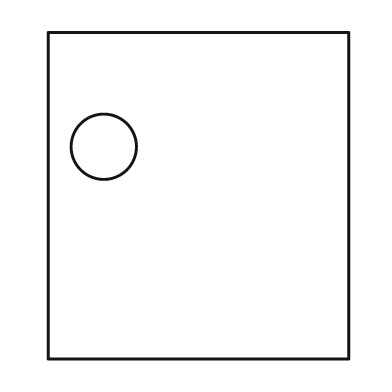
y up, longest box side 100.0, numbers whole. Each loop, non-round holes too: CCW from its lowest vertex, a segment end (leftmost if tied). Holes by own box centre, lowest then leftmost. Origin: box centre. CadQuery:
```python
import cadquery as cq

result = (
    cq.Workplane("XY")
    .moveTo(-46.0, -50.0)
    .lineTo(46.0, -50.0)
    .lineTo(46.0, 50.0)
    .lineTo(-46.0, 50.0)
    .close()
    .moveTo(-29.0, 15.0)
    .circle(10.0)
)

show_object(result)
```